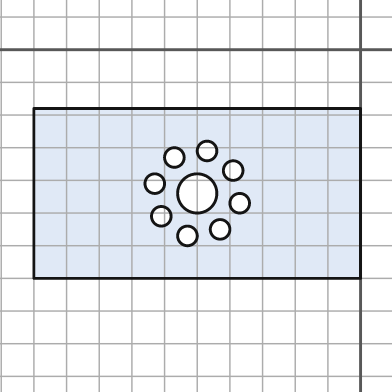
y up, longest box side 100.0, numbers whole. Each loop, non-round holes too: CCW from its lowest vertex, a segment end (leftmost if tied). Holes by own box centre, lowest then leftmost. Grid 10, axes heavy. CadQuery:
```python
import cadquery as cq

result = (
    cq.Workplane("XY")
    .moveTo(-100.0, -70.0)
    .lineTo(0.0, -70.0)
    .lineTo(0.0, -18.0)
    .lineTo(-100.0, -18.0)
    .close()
    .moveTo(-53.0, -57.0)
    .circle(3.0)
    .moveTo(-43.0, -55.0)
    .circle(3.0)
    .moveTo(-61.0, -51.0)
    .circle(3.0)
    .moveTo(-37.0, -47.0)
    .circle(3.0)
    .moveTo(-50.0, -44.0)
    .circle(6.0)
    .moveTo(-63.0, -41.0)
    .circle(3.0)
    .moveTo(-39.0, -37.0)
    .circle(3.0)
    .moveTo(-57.0, -33.0)
    .circle(3.0)
    .moveTo(-47.0, -31.0)
    .circle(3.0)
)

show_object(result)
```